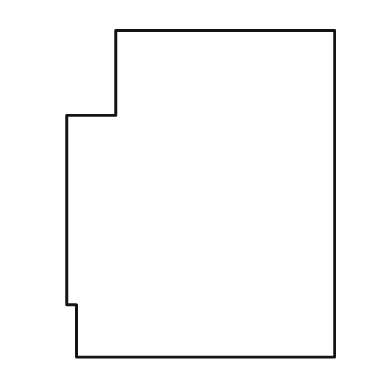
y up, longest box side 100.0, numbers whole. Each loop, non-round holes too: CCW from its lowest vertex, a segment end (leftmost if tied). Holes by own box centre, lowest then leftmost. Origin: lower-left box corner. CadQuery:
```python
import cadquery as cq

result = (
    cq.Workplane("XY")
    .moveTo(3.0, 0.0)
    .lineTo(82.0, 0.0)
    .lineTo(82.0, 100.0)
    .lineTo(15.0, 100.0)
    .lineTo(15.0, 74.0)
    .lineTo(0.0, 74.0)
    .lineTo(0.0, 16.0)
    .lineTo(3.0, 16.0)
    .close()
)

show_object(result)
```